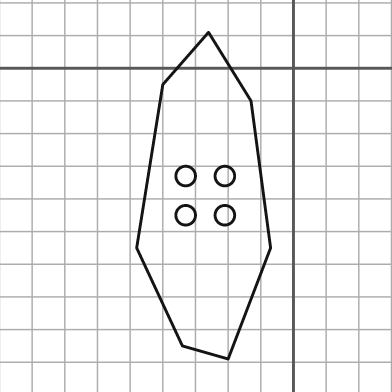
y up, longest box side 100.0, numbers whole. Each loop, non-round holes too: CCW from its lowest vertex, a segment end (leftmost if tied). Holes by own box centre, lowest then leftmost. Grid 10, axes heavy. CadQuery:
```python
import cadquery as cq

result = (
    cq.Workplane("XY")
    .moveTo(-20.0, -89.0)
    .lineTo(-7.0, -55.0)
    .lineTo(-13.0, -10.0)
    .lineTo(-26.0, 11.0)
    .lineTo(-40.0, -5.0)
    .lineTo(-48.0, -55.0)
    .lineTo(-34.0, -85.0)
    .close()
    .moveTo(-33.0, -45.0)
    .circle(3.0)
    .moveTo(-21.0, -45.0)
    .circle(3.0)
    .moveTo(-33.0, -33.0)
    .circle(3.0)
    .moveTo(-21.0, -33.0)
    .circle(3.0)
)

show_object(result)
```